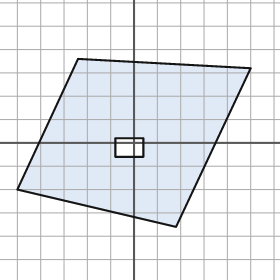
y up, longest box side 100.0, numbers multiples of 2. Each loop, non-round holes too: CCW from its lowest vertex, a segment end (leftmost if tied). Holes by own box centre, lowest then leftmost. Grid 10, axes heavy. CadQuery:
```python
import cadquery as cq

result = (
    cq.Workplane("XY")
    .moveTo(18.0, -36.0)
    .lineTo(50.0, 32.0)
    .lineTo(-24.0, 36.0)
    .lineTo(-50.0, -20.0)
    .close()
    .moveTo(-8.0, -6.0)
    .lineTo(4.0, -6.0)
    .lineTo(4.0, 2.0)
    .lineTo(-8.0, 2.0)
    .close()
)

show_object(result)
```